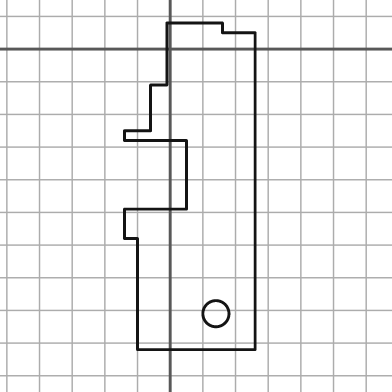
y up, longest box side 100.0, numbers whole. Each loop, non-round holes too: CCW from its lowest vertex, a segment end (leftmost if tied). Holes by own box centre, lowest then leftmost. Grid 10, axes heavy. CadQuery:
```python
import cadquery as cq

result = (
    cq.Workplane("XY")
    .moveTo(-10.0, -92.0)
    .lineTo(26.0, -92.0)
    .lineTo(26.0, 5.0)
    .lineTo(16.0, 5.0)
    .lineTo(16.0, 8.0)
    .lineTo(-1.0, 8.0)
    .lineTo(-1.0, -11.0)
    .lineTo(-6.0, -11.0)
    .lineTo(-6.0, -25.0)
    .lineTo(-14.0, -25.0)
    .lineTo(-14.0, -28.0)
    .lineTo(5.0, -28.0)
    .lineTo(5.0, -49.0)
    .lineTo(-14.0, -49.0)
    .lineTo(-14.0, -58.0)
    .lineTo(-10.0, -58.0)
    .close()
    .moveTo(14.0, -81.0)
    .circle(4.0)
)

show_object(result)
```